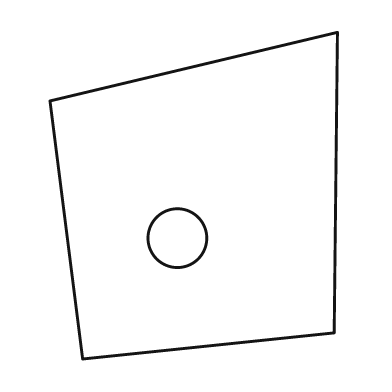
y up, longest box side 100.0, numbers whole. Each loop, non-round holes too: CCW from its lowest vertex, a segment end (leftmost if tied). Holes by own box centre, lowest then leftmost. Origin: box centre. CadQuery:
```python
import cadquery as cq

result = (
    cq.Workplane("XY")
    .moveTo(-34.0, -50.0)
    .lineTo(43.0, -42.0)
    .lineTo(44.0, 50.0)
    .lineTo(-44.0, 29.0)
    .close()
    .moveTo(-5.0, -13.0)
    .circle(9.0)
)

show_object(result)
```